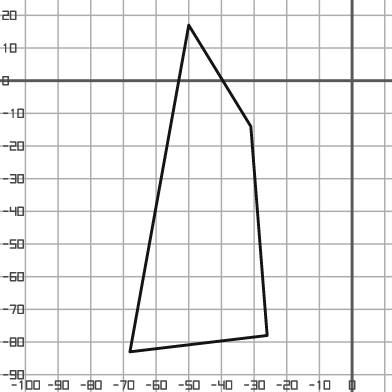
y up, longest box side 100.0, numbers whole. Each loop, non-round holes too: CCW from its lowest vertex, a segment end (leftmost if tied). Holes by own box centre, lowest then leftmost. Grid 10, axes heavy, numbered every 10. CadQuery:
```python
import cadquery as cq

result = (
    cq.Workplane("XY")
    .moveTo(-68.0, -83.0)
    .lineTo(-26.0, -78.0)
    .lineTo(-31.0, -14.0)
    .lineTo(-50.0, 17.0)
    .close()
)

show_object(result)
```